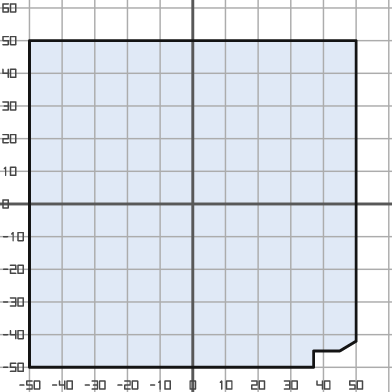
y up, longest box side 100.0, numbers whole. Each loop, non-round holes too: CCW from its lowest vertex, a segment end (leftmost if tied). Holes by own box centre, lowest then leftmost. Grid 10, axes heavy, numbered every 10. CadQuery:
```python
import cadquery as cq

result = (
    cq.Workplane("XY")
    .moveTo(-50.0, -50.0)
    .lineTo(37.0, -50.0)
    .lineTo(37.0, -45.0)
    .lineTo(45.0, -45.0)
    .lineTo(50.0, -42.0)
    .lineTo(50.0, 50.0)
    .lineTo(-50.0, 50.0)
    .close()
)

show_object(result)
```